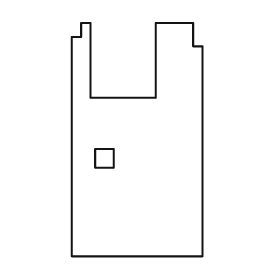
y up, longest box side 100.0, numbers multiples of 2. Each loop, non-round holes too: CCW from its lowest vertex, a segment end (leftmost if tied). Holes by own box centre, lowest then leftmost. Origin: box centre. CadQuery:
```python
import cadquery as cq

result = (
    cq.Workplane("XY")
    .moveTo(-28.0, -50.0)
    .lineTo(28.0, -50.0)
    .lineTo(28.0, 40.0)
    .lineTo(24.0, 40.0)
    .lineTo(24.0, 50.0)
    .lineTo(8.0, 50.0)
    .lineTo(8.0, 18.0)
    .lineTo(-20.0, 18.0)
    .lineTo(-20.0, 50.0)
    .lineTo(-24.0, 50.0)
    .lineTo(-24.0, 44.0)
    .lineTo(-28.0, 44.0)
    .close()
    .moveTo(-18.0, -12.0)
    .lineTo(-10.0, -12.0)
    .lineTo(-10.0, -4.0)
    .lineTo(-18.0, -4.0)
    .close()
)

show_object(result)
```